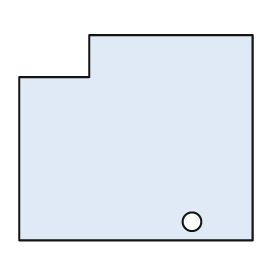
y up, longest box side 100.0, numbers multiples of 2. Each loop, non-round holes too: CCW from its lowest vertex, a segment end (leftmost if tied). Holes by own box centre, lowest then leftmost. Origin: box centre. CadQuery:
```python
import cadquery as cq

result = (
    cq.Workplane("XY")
    .moveTo(-50.0, -44.0)
    .lineTo(50.0, -44.0)
    .lineTo(50.0, 44.0)
    .lineTo(-20.0, 44.0)
    .lineTo(-20.0, 26.0)
    .lineTo(-50.0, 26.0)
    .close()
    .moveTo(24.0, -36.0)
    .circle(4.0)
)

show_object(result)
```